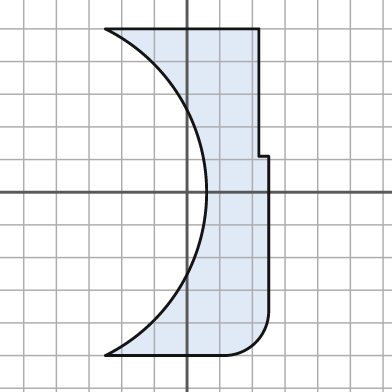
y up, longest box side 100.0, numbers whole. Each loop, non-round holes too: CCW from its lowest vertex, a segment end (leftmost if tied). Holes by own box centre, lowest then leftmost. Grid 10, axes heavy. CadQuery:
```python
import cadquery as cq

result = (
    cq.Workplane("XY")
    .moveTo(-25.0, -50.0)
    .lineTo(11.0, -50.0)
    .threePointArc((21.0, -46.0), (25.0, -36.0))
    .lineTo(25.0, 11.0)
    .lineTo(22.0, 11.0)
    .lineTo(22.0, 50.0)
    .lineTo(-25.0, 50.0)
    .threePointArc((6.0, 0.0), (-25.0, -50.0))
    .close()
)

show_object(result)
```